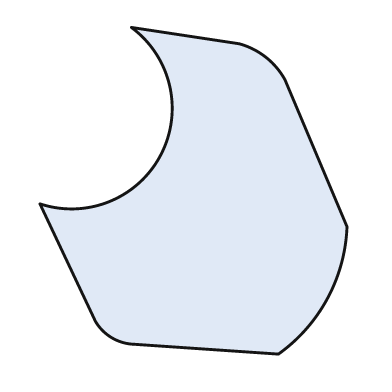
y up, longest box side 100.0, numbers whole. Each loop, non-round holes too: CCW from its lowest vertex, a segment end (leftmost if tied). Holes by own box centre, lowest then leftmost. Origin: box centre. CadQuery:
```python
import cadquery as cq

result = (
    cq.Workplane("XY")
    .moveTo(26.0, -50.0)
    .threePointArc((41.0, -33.0), (47.0, -11.0))
    .lineTo(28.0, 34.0)
    .threePointArc((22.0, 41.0), (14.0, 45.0))
    .lineTo(-19.0, 50.0)
    .threePointArc((-10.0, 11.0), (-47.0, -4.0))
    .lineTo(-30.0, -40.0)
    .threePointArc((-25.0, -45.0), (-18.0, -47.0))
    .close()
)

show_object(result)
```